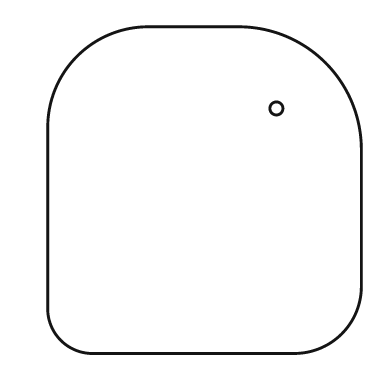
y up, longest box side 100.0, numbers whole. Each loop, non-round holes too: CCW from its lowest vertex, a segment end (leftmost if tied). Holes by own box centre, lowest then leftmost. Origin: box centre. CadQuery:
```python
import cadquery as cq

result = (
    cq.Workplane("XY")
    .moveTo(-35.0, -50.0)
    .lineTo(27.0, -50.0)
    .threePointArc((42.0, -44.0), (48.0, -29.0))
    .lineTo(48.0, 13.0)
    .threePointArc((37.0, 39.0), (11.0, 50.0))
    .lineTo(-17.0, 50.0)
    .threePointArc((-39.0, 41.0), (-48.0, 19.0))
    .lineTo(-48.0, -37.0)
    .threePointArc((-44.0, -46.0), (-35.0, -50.0))
    .close()
    .moveTo(22.0, 25.0)
    .circle(2.0)
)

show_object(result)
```